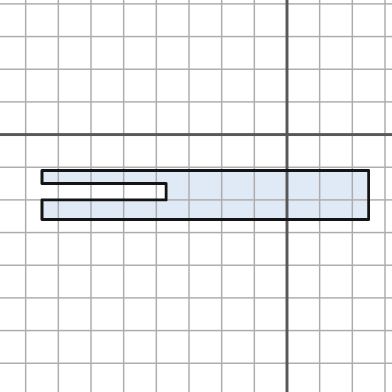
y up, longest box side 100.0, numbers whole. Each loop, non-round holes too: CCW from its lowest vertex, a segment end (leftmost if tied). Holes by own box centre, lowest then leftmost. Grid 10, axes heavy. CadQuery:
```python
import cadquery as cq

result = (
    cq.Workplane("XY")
    .moveTo(-75.0, -26.0)
    .lineTo(25.0, -26.0)
    .lineTo(25.0, -11.0)
    .lineTo(-75.0, -11.0)
    .lineTo(-75.0, -15.0)
    .lineTo(-37.0, -15.0)
    .lineTo(-37.0, -20.0)
    .lineTo(-75.0, -20.0)
    .close()
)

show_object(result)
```